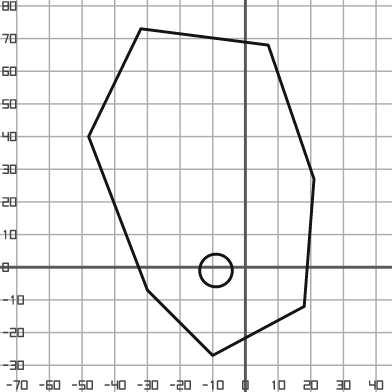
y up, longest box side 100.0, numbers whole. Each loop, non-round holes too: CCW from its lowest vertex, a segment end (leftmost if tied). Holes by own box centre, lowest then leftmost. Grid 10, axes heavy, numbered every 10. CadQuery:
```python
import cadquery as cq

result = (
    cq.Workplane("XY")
    .moveTo(-10.0, -27.0)
    .lineTo(18.0, -12.0)
    .lineTo(21.0, 27.0)
    .lineTo(7.0, 68.0)
    .lineTo(-32.0, 73.0)
    .lineTo(-48.0, 40.0)
    .lineTo(-30.0, -7.0)
    .close()
    .moveTo(-9.0, -1.0)
    .circle(5.0)
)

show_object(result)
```